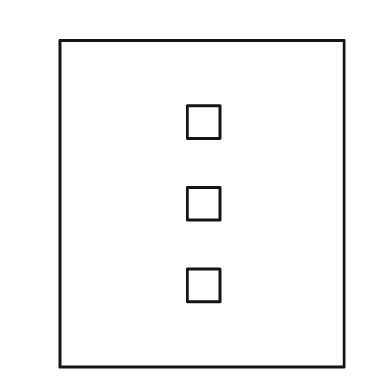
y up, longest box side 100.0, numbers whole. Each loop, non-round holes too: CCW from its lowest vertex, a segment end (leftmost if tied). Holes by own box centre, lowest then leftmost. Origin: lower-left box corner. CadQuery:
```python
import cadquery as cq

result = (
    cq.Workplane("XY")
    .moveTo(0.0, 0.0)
    .lineTo(87.0, 0.0)
    .lineTo(87.0, 100.0)
    .lineTo(0.0, 100.0)
    .close()
    .moveTo(39.0, 20.0)
    .lineTo(49.0, 20.0)
    .lineTo(49.0, 30.0)
    .lineTo(39.0, 30.0)
    .close()
    .moveTo(39.0, 45.0)
    .lineTo(49.0, 45.0)
    .lineTo(49.0, 55.0)
    .lineTo(39.0, 55.0)
    .close()
    .moveTo(39.0, 70.0)
    .lineTo(49.0, 70.0)
    .lineTo(49.0, 80.0)
    .lineTo(39.0, 80.0)
    .close()
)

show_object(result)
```